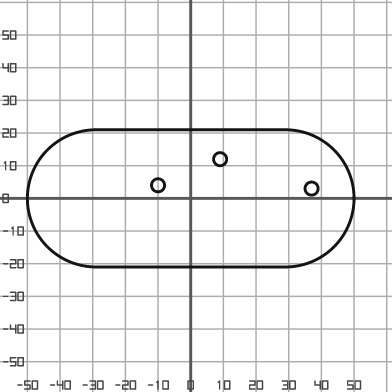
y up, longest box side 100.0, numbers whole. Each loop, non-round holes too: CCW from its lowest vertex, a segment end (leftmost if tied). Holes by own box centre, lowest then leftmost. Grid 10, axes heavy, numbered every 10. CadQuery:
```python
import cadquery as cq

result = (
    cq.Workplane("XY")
    .moveTo(-29.0, -21.0)
    .lineTo(29.0, -21.0)
    .threePointArc((50.0, 0.0), (29.0, 21.0))
    .lineTo(-29.0, 21.0)
    .threePointArc((-50.0, 0.0), (-29.0, -21.0))
    .close()
    .moveTo(37.0, 3.0)
    .circle(2.0)
    .moveTo(-10.0, 4.0)
    .circle(2.0)
    .moveTo(9.0, 12.0)
    .circle(2.0)
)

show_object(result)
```